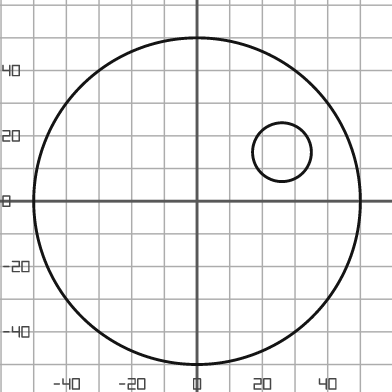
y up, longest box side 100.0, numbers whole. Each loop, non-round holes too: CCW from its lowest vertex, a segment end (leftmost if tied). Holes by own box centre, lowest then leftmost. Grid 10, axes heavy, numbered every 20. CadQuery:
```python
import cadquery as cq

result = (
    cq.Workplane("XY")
    .moveTo(0.0, 0.0)
    .circle(50.0)
    .moveTo(26.0, 15.0)
    .circle(9.0)
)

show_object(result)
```